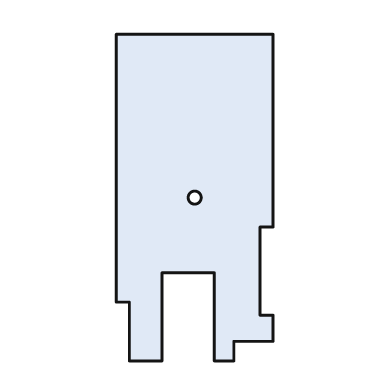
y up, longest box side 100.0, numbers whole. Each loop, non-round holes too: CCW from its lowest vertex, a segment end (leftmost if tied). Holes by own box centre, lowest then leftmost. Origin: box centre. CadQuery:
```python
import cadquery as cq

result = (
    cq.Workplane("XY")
    .moveTo(-20.0, -50.0)
    .lineTo(-10.0, -50.0)
    .lineTo(-10.0, -23.0)
    .lineTo(6.0, -23.0)
    .lineTo(6.0, -50.0)
    .lineTo(12.0, -50.0)
    .lineTo(12.0, -44.0)
    .lineTo(24.0, -44.0)
    .lineTo(24.0, -36.0)
    .lineTo(20.0, -36.0)
    .lineTo(20.0, -9.0)
    .lineTo(24.0, -9.0)
    .lineTo(24.0, 50.0)
    .lineTo(-24.0, 50.0)
    .lineTo(-24.0, -32.0)
    .lineTo(-20.0, -32.0)
    .close()
    .moveTo(0.0, 0.0)
    .circle(2.0)
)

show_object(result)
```